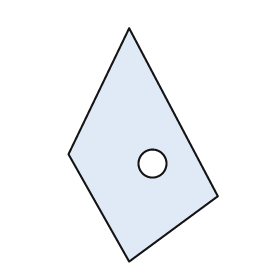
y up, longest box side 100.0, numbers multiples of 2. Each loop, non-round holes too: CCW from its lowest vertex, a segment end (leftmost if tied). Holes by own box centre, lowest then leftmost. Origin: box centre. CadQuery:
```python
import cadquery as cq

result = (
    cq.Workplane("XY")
    .moveTo(-6.0, -50.0)
    .lineTo(32.0, -22.0)
    .lineTo(-6.0, 50.0)
    .lineTo(-32.0, -4.0)
    .close()
    .moveTo(4.0, -8.0)
    .circle(6.0)
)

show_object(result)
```